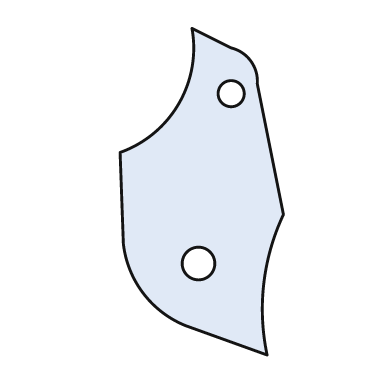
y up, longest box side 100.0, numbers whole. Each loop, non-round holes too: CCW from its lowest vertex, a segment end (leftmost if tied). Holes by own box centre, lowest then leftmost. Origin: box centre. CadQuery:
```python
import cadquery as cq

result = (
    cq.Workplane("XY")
    .moveTo(20.0, -50.0)
    .threePointArc((19.0, -28.0), (25.0, -7.0))
    .lineTo(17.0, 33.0)
    .threePointArc((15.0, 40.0), (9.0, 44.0))
    .lineTo(-3.0, 50.0)
    .threePointArc((-7.0, 27.0), (-25.0, 12.0))
    .lineTo(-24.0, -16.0)
    .threePointArc((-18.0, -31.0), (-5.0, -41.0))
    .close()
    .moveTo(-1.0, -22.0)
    .circle(5.0)
    .moveTo(9.0, 30.0)
    .circle(4.0)
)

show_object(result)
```